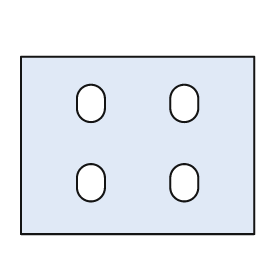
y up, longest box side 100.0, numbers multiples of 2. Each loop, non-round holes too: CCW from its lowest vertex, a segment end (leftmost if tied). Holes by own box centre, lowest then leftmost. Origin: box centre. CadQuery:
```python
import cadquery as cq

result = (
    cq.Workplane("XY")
    .moveTo(-50.0, -38.0)
    .lineTo(50.0, -38.0)
    .lineTo(50.0, 38.0)
    .lineTo(-50.0, 38.0)
    .close()
    .moveTo(-26.0, -18.0)
    .threePointArc((-20.0, -24.0), (-14.0, -18.0))
    .lineTo(-14.0, -14.0)
    .threePointArc((-20.0, -8.0), (-26.0, -14.0))
    .close()
    .moveTo(14.0, -18.0)
    .threePointArc((20.0, -24.0), (26.0, -18.0))
    .lineTo(26.0, -14.0)
    .threePointArc((20.0, -8.0), (14.0, -14.0))
    .close()
    .moveTo(-26.0, 16.0)
    .threePointArc((-20.0, 10.0), (-14.0, 16.0))
    .lineTo(-14.0, 20.0)
    .threePointArc((-20.0, 26.0), (-26.0, 20.0))
    .close()
    .moveTo(14.0, 16.0)
    .threePointArc((20.0, 10.0), (26.0, 16.0))
    .lineTo(26.0, 20.0)
    .threePointArc((20.0, 26.0), (14.0, 20.0))
    .close()
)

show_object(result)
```